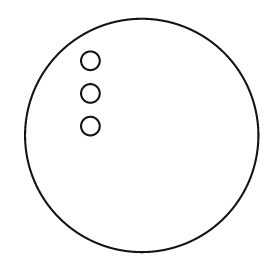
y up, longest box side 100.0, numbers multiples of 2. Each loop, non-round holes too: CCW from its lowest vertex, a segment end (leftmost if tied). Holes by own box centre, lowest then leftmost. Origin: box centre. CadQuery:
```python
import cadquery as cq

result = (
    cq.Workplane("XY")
    .moveTo(0.0, 0.0)
    .circle(50.0)
    .moveTo(-22.0, 4.0)
    .circle(4.0)
    .moveTo(-22.0, 18.0)
    .circle(4.0)
    .moveTo(-22.0, 32.0)
    .circle(4.0)
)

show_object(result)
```